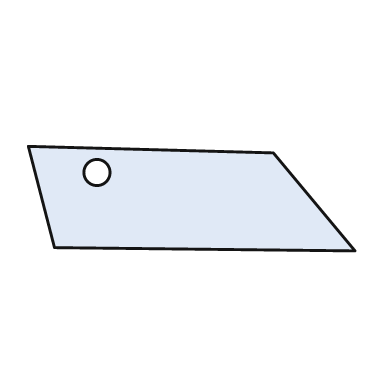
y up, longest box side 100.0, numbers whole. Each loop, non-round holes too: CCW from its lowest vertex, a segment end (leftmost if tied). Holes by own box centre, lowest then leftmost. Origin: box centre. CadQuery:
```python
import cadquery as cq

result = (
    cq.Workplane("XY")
    .moveTo(50.0, -16.0)
    .lineTo(25.0, 14.0)
    .lineTo(-50.0, 16.0)
    .lineTo(-42.0, -15.0)
    .close()
    .moveTo(-29.0, 8.0)
    .circle(4.0)
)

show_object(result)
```